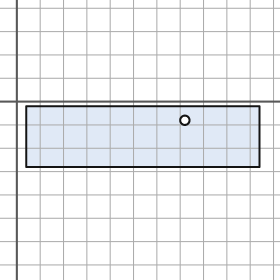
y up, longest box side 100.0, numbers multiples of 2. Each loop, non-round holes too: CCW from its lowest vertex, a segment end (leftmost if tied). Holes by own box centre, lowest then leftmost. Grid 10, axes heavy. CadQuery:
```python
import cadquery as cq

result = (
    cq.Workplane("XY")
    .moveTo(4.0, -28.0)
    .lineTo(104.0, -28.0)
    .lineTo(104.0, -2.0)
    .lineTo(4.0, -2.0)
    .close()
    .moveTo(72.0, -8.0)
    .circle(2.0)
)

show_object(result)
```